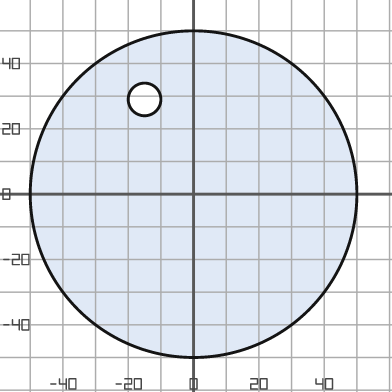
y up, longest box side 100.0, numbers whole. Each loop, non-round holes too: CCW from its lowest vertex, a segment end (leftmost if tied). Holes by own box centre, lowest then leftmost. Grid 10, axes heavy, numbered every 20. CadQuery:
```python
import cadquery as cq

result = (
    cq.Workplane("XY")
    .moveTo(0.0, 0.0)
    .circle(50.0)
    .moveTo(-15.0, 29.0)
    .circle(5.0)
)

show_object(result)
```